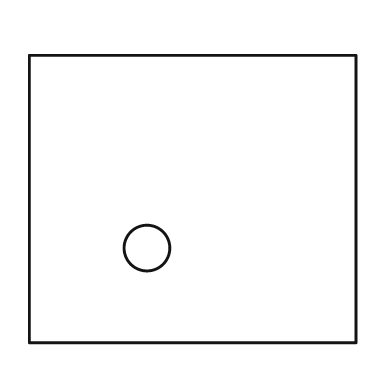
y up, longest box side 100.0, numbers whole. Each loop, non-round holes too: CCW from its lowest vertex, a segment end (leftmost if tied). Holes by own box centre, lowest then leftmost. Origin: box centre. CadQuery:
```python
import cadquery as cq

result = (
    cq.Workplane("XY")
    .moveTo(-50.0, -44.0)
    .lineTo(50.0, -44.0)
    .lineTo(50.0, 44.0)
    .lineTo(-50.0, 44.0)
    .close()
    .moveTo(-14.0, -15.0)
    .circle(7.0)
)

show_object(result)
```